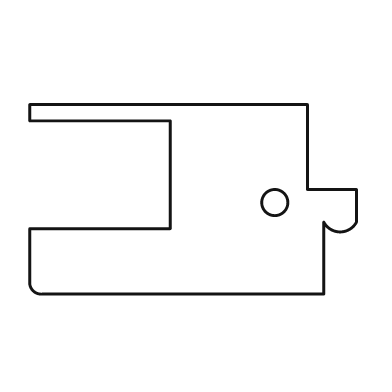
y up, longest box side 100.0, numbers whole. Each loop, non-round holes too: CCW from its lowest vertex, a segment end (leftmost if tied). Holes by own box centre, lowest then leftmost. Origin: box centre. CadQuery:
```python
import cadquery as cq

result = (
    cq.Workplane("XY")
    .moveTo(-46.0, -29.0)
    .lineTo(40.0, -29.0)
    .lineTo(40.0, -7.0)
    .threePointArc((45.0, -10.0), (50.0, -7.0))
    .lineTo(50.0, 3.0)
    .lineTo(35.0, 3.0)
    .lineTo(35.0, 29.0)
    .lineTo(-50.0, 29.0)
    .lineTo(-50.0, 24.0)
    .lineTo(-7.0, 24.0)
    .lineTo(-7.0, -9.0)
    .lineTo(-50.0, -9.0)
    .lineTo(-50.0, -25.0)
    .threePointArc((-49.0, -28.0), (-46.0, -29.0))
    .close()
    .moveTo(25.0, -1.0)
    .circle(4.0)
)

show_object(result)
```